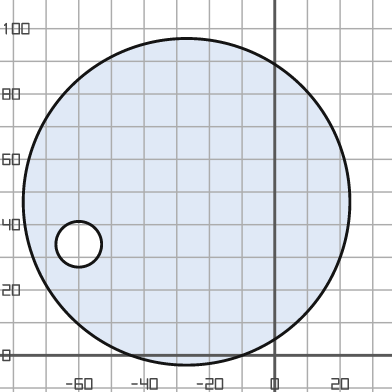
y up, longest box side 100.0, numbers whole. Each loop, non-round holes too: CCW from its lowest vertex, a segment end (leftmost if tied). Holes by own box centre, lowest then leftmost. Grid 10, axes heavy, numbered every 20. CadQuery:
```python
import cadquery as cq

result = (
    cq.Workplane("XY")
    .moveTo(-27.0, 47.0)
    .circle(50.0)
    .moveTo(-60.0, 34.0)
    .circle(7.0)
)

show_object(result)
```